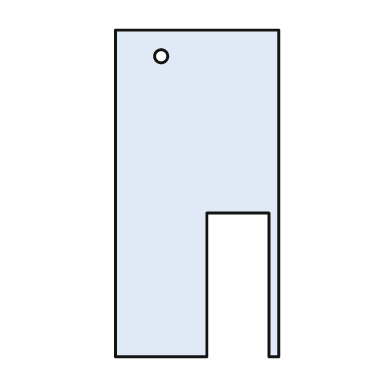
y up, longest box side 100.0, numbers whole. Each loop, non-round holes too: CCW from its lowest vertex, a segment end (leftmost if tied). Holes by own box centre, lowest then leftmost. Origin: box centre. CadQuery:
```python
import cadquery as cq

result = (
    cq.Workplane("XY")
    .moveTo(-25.0, -50.0)
    .lineTo(3.0, -50.0)
    .lineTo(3.0, -6.0)
    .lineTo(22.0, -6.0)
    .lineTo(22.0, -50.0)
    .lineTo(25.0, -50.0)
    .lineTo(25.0, 50.0)
    .lineTo(-25.0, 50.0)
    .close()
    .moveTo(-11.0, 42.0)
    .circle(2.0)
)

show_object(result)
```